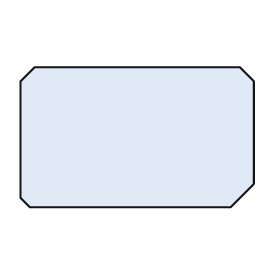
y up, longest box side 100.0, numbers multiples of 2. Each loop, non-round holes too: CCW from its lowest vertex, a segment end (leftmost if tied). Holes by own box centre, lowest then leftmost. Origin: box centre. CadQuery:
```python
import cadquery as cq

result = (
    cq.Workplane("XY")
    .moveTo(-46.0, -30.0)
    .lineTo(40.0, -30.0)
    .lineTo(50.0, -20.0)
    .lineTo(50.0, 24.0)
    .lineTo(44.0, 30.0)
    .lineTo(-44.0, 30.0)
    .lineTo(-50.0, 24.0)
    .lineTo(-50.0, -26.0)
    .close()
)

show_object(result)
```